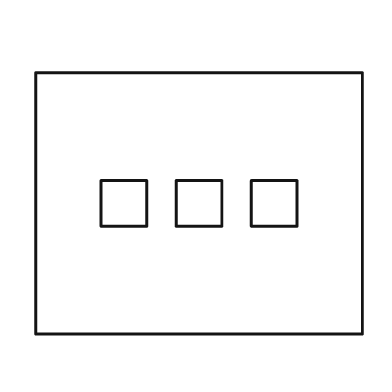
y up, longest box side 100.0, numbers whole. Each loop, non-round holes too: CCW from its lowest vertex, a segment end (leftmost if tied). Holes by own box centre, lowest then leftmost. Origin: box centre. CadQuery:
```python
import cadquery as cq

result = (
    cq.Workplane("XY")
    .moveTo(-50.0, -40.0)
    .lineTo(50.0, -40.0)
    .lineTo(50.0, 40.0)
    .lineTo(-50.0, 40.0)
    .close()
    .moveTo(-30.0, -7.0)
    .lineTo(-16.0, -7.0)
    .lineTo(-16.0, 7.0)
    .lineTo(-30.0, 7.0)
    .close()
    .moveTo(-7.0, -7.0)
    .lineTo(7.0, -7.0)
    .lineTo(7.0, 7.0)
    .lineTo(-7.0, 7.0)
    .close()
    .moveTo(16.0, -7.0)
    .lineTo(30.0, -7.0)
    .lineTo(30.0, 7.0)
    .lineTo(16.0, 7.0)
    .close()
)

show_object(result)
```